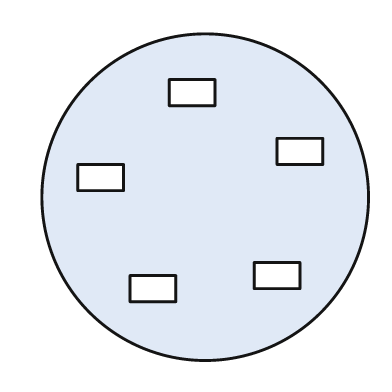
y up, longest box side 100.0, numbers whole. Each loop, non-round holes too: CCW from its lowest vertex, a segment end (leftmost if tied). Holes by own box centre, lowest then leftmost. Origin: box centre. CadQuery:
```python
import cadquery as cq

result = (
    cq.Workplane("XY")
    .moveTo(0.0, 0.0)
    .circle(50.0)
    .moveTo(-23.0, -32.0)
    .lineTo(-9.0, -32.0)
    .lineTo(-9.0, -24.0)
    .lineTo(-23.0, -24.0)
    .close()
    .moveTo(15.0, -28.0)
    .lineTo(29.0, -28.0)
    .lineTo(29.0, -20.0)
    .lineTo(15.0, -20.0)
    .close()
    .moveTo(-39.0, 2.0)
    .lineTo(-25.0, 2.0)
    .lineTo(-25.0, 10.0)
    .lineTo(-39.0, 10.0)
    .close()
    .moveTo(22.0, 10.0)
    .lineTo(36.0, 10.0)
    .lineTo(36.0, 18.0)
    .lineTo(22.0, 18.0)
    .close()
    .moveTo(-11.0, 28.0)
    .lineTo(3.0, 28.0)
    .lineTo(3.0, 36.0)
    .lineTo(-11.0, 36.0)
    .close()
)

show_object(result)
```